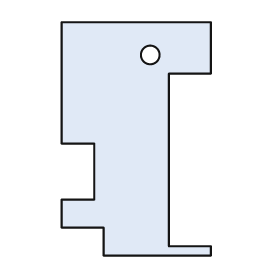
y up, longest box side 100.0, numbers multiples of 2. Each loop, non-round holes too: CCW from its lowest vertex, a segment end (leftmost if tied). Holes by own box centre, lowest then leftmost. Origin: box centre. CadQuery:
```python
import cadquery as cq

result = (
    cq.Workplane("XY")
    .moveTo(-14.0, -50.0)
    .lineTo(32.0, -50.0)
    .lineTo(32.0, -46.0)
    .lineTo(14.0, -46.0)
    .lineTo(14.0, 28.0)
    .lineTo(32.0, 28.0)
    .lineTo(32.0, 50.0)
    .lineTo(-32.0, 50.0)
    .lineTo(-32.0, -2.0)
    .lineTo(-18.0, -2.0)
    .lineTo(-18.0, -26.0)
    .lineTo(-32.0, -26.0)
    .lineTo(-32.0, -38.0)
    .lineTo(-14.0, -38.0)
    .close()
    .moveTo(6.0, 36.0)
    .circle(4.0)
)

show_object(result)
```